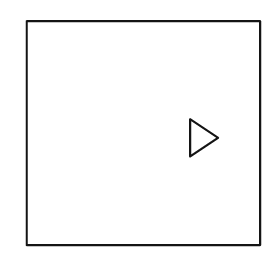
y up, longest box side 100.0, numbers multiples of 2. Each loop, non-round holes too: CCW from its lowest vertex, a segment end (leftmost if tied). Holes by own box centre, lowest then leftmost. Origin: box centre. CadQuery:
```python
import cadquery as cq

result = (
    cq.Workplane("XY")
    .moveTo(-50.0, -48.0)
    .lineTo(50.0, -48.0)
    .lineTo(50.0, 48.0)
    .lineTo(-50.0, 48.0)
    .close()
    .moveTo(20.0, -10.0)
    .lineTo(32.0, -2.0)
    .lineTo(20.0, 6.0)
    .close()
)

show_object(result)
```